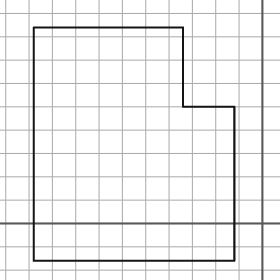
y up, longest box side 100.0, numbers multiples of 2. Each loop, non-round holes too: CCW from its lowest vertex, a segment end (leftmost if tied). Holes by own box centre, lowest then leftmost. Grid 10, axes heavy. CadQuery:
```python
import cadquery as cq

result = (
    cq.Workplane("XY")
    .moveTo(-98.0, -16.0)
    .lineTo(-12.0, -16.0)
    .lineTo(-12.0, 50.0)
    .lineTo(-34.0, 50.0)
    .lineTo(-34.0, 84.0)
    .lineTo(-98.0, 84.0)
    .close()
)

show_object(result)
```